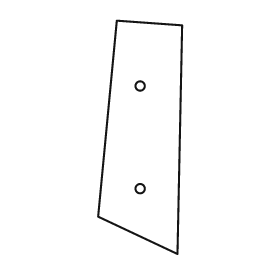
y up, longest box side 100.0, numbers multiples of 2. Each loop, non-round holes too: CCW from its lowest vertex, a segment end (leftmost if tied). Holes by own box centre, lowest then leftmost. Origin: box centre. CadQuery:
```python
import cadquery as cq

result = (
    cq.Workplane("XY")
    .moveTo(16.0, -50.0)
    .lineTo(18.0, 48.0)
    .lineTo(-10.0, 50.0)
    .lineTo(-18.0, -34.0)
    .close()
    .moveTo(0.0, -22.0)
    .circle(2.0)
    .moveTo(0.0, 22.0)
    .circle(2.0)
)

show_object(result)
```